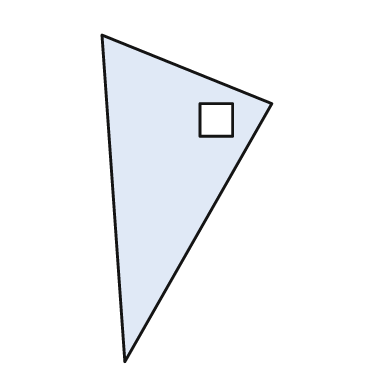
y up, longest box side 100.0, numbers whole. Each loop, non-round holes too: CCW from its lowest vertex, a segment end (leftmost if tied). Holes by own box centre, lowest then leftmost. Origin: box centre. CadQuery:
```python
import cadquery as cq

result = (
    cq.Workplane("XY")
    .moveTo(-19.0, -50.0)
    .lineTo(26.0, 29.0)
    .lineTo(-26.0, 50.0)
    .close()
    .moveTo(4.0, 19.0)
    .lineTo(14.0, 19.0)
    .lineTo(14.0, 29.0)
    .lineTo(4.0, 29.0)
    .close()
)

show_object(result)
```